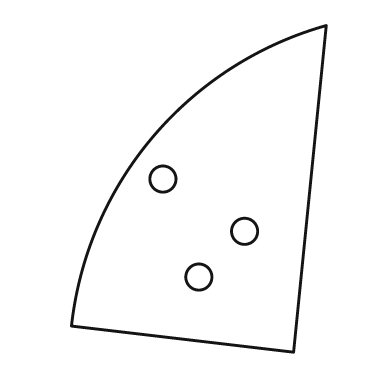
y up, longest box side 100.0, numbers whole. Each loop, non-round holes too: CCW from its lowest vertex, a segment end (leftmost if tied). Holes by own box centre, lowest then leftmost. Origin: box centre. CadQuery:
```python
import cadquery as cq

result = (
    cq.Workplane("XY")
    .moveTo(29.0, -50.0)
    .lineTo(39.0, 50.0)
    .threePointArc((-14.0, 16.0), (-39.0, -42.0))
    .close()
    .moveTo(0.0, -27.0)
    .circle(4.0)
    .moveTo(14.0, -13.0)
    .circle(4.0)
    .moveTo(-11.0, 3.0)
    .circle(4.0)
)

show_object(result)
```